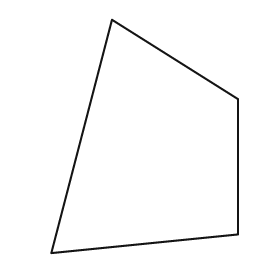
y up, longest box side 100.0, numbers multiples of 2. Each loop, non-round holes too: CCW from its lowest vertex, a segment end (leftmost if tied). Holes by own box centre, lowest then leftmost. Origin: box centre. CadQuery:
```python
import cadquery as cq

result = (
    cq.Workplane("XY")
    .moveTo(-40.0, -50.0)
    .lineTo(40.0, -42.0)
    .lineTo(40.0, 16.0)
    .lineTo(-14.0, 50.0)
    .close()
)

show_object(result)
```